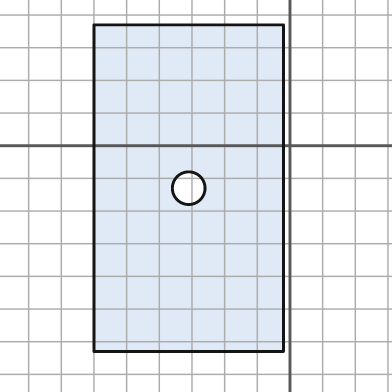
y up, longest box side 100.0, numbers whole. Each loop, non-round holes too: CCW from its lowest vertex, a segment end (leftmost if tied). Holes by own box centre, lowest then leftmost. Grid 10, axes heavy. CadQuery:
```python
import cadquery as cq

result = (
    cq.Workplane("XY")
    .moveTo(-60.0, -63.0)
    .lineTo(-2.0, -63.0)
    .lineTo(-2.0, 37.0)
    .lineTo(-60.0, 37.0)
    .close()
    .moveTo(-31.0, -13.0)
    .circle(5.0)
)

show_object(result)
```